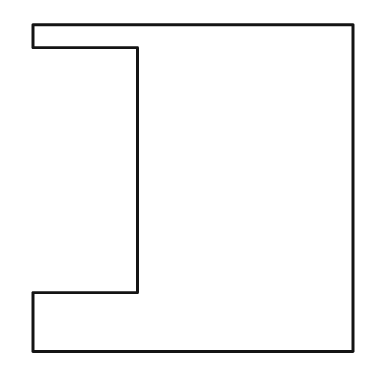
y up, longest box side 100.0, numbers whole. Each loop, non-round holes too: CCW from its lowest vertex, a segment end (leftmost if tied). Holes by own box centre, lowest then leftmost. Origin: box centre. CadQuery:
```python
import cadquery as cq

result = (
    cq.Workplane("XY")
    .moveTo(-49.0, -50.0)
    .lineTo(49.0, -50.0)
    .lineTo(49.0, 50.0)
    .lineTo(-49.0, 50.0)
    .lineTo(-49.0, 43.0)
    .lineTo(-17.0, 43.0)
    .lineTo(-17.0, -32.0)
    .lineTo(-49.0, -32.0)
    .close()
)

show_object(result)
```